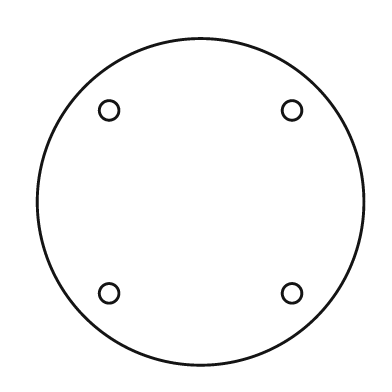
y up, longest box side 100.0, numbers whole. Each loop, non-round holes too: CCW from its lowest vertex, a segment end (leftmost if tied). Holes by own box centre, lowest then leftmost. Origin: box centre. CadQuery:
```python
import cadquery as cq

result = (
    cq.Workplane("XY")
    .moveTo(0.0, 0.0)
    .circle(50.0)
    .moveTo(-28.0, -28.0)
    .circle(3.0)
    .moveTo(28.0, -28.0)
    .circle(3.0)
    .moveTo(-28.0, 28.0)
    .circle(3.0)
    .moveTo(28.0, 28.0)
    .circle(3.0)
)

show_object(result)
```